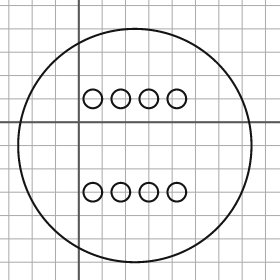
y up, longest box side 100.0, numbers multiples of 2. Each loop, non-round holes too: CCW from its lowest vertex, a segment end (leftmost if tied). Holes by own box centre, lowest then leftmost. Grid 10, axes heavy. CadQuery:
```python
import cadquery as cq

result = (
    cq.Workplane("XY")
    .moveTo(24.0, -10.0)
    .circle(50.0)
    .moveTo(6.0, -30.0)
    .circle(4.0)
    .moveTo(18.0, -30.0)
    .circle(4.0)
    .moveTo(30.0, -30.0)
    .circle(4.0)
    .moveTo(42.0, -30.0)
    .circle(4.0)
    .moveTo(6.0, 10.0)
    .circle(4.0)
    .moveTo(18.0, 10.0)
    .circle(4.0)
    .moveTo(30.0, 10.0)
    .circle(4.0)
    .moveTo(42.0, 10.0)
    .circle(4.0)
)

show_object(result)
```